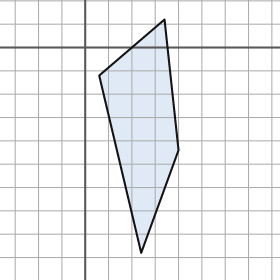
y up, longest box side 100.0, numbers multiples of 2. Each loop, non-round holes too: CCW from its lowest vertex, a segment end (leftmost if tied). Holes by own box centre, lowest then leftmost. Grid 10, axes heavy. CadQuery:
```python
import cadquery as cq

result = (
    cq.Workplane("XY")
    .moveTo(24.0, -88.0)
    .lineTo(40.0, -44.0)
    .lineTo(34.0, 12.0)
    .lineTo(6.0, -12.0)
    .close()
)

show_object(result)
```